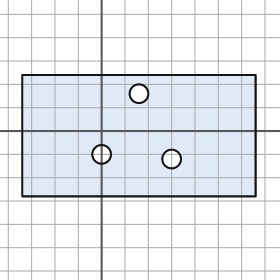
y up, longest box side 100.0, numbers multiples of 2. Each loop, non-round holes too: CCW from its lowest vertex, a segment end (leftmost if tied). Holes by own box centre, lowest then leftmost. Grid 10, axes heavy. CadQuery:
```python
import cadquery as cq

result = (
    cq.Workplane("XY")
    .moveTo(-34.0, -28.0)
    .lineTo(66.0, -28.0)
    .lineTo(66.0, 24.0)
    .lineTo(-34.0, 24.0)
    .close()
    .moveTo(30.0, -12.0)
    .circle(4.0)
    .moveTo(0.0, -10.0)
    .circle(4.0)
    .moveTo(16.0, 16.0)
    .circle(4.0)
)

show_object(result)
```